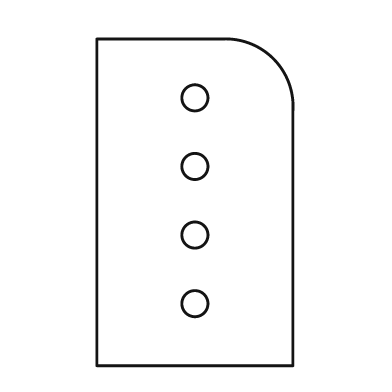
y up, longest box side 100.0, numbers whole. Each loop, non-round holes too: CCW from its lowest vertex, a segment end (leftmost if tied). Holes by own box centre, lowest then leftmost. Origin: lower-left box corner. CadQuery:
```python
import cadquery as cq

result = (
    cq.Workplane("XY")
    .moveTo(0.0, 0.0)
    .lineTo(60.0, 0.0)
    .lineTo(60.0, 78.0)
    .threePointArc((54.0, 94.0), (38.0, 100.0))
    .lineTo(0.0, 100.0)
    .close()
    .moveTo(30.0, 19.0)
    .circle(4.0)
    .moveTo(30.0, 40.0)
    .circle(4.0)
    .moveTo(30.0, 61.0)
    .circle(4.0)
    .moveTo(30.0, 82.0)
    .circle(4.0)
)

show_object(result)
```